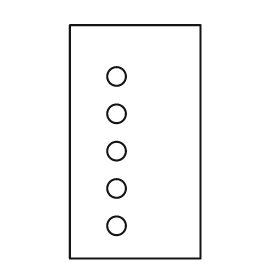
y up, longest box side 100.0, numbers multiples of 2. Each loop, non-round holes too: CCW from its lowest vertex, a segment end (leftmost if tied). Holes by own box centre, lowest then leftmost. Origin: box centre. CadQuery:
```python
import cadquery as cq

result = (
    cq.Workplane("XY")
    .moveTo(-28.0, -50.0)
    .lineTo(28.0, -50.0)
    .lineTo(28.0, 50.0)
    .lineTo(-28.0, 50.0)
    .close()
    .moveTo(-8.0, -36.0)
    .circle(4.0)
    .moveTo(-8.0, -20.0)
    .circle(4.0)
    .moveTo(-8.0, -4.0)
    .circle(4.0)
    .moveTo(-8.0, 12.0)
    .circle(4.0)
    .moveTo(-8.0, 28.0)
    .circle(4.0)
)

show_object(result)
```